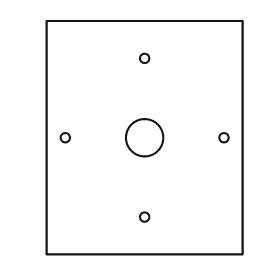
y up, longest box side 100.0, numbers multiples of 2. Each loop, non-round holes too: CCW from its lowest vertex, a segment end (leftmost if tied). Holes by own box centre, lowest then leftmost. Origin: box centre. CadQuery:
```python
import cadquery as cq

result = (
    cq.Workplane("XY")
    .moveTo(-42.0, -50.0)
    .lineTo(42.0, -50.0)
    .lineTo(42.0, 50.0)
    .lineTo(-42.0, 50.0)
    .close()
    .moveTo(0.0, -34.0)
    .circle(2.0)
    .moveTo(-34.0, 0.0)
    .circle(2.0)
    .moveTo(0.0, 0.0)
    .circle(8.0)
    .moveTo(34.0, 0.0)
    .circle(2.0)
    .moveTo(0.0, 34.0)
    .circle(2.0)
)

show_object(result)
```